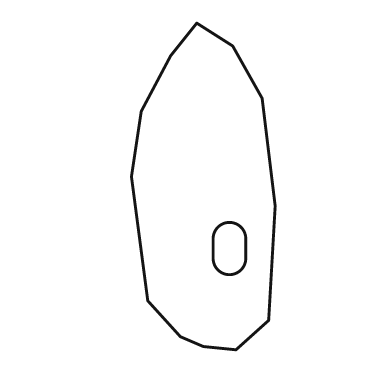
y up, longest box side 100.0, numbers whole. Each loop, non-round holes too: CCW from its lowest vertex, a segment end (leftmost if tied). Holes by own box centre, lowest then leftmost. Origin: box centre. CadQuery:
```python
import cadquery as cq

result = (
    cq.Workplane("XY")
    .moveTo(10.0, -50.0)
    .lineTo(20.0, -41.0)
    .lineTo(22.0, -6.0)
    .lineTo(18.0, 27.0)
    .lineTo(9.0, 43.0)
    .lineTo(-2.0, 50.0)
    .lineTo(-10.0, 40.0)
    .lineTo(-19.0, 23.0)
    .lineTo(-22.0, 3.0)
    .lineTo(-17.0, -35.0)
    .lineTo(-7.0, -46.0)
    .lineTo(0.0, -49.0)
    .close()
    .moveTo(3.0, -22.0)
    .threePointArc((8.0, -27.0), (13.0, -22.0))
    .lineTo(13.0, -16.0)
    .threePointArc((8.0, -11.0), (3.0, -16.0))
    .close()
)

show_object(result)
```